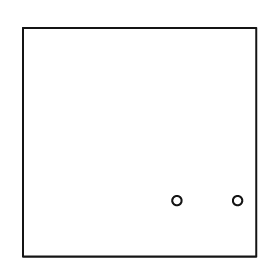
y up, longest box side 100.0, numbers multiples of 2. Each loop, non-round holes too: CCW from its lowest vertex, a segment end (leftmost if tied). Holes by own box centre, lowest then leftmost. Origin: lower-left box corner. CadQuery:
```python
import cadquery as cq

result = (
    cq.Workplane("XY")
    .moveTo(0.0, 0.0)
    .lineTo(100.0, 0.0)
    .lineTo(100.0, 98.0)
    .lineTo(0.0, 98.0)
    .close()
    .moveTo(66.0, 24.0)
    .circle(2.0)
    .moveTo(92.0, 24.0)
    .circle(2.0)
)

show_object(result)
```